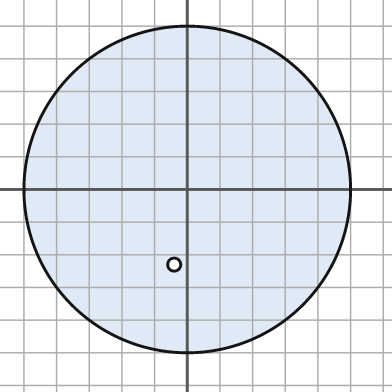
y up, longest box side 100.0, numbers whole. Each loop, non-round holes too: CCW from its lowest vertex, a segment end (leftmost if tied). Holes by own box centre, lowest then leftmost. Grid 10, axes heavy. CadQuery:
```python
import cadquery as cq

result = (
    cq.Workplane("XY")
    .moveTo(0.0, 0.0)
    .circle(50.0)
    .moveTo(-4.0, -23.0)
    .circle(2.0)
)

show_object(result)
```